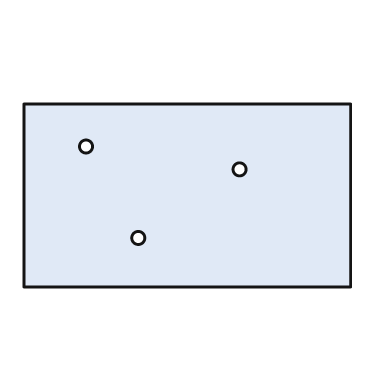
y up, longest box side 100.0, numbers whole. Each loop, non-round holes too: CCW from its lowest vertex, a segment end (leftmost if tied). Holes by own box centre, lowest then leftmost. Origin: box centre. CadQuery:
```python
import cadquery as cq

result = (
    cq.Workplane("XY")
    .moveTo(-50.0, -28.0)
    .lineTo(50.0, -28.0)
    .lineTo(50.0, 28.0)
    .lineTo(-50.0, 28.0)
    .close()
    .moveTo(-15.0, -13.0)
    .circle(2.0)
    .moveTo(16.0, 8.0)
    .circle(2.0)
    .moveTo(-31.0, 15.0)
    .circle(2.0)
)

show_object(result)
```